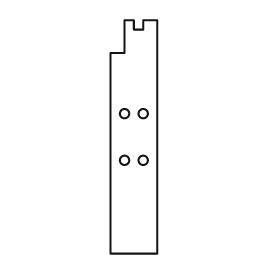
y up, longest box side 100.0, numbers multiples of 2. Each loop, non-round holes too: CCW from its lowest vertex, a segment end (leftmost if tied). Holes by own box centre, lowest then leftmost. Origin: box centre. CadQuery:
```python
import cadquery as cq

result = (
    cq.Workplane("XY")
    .moveTo(-10.0, -50.0)
    .lineTo(10.0, -50.0)
    .lineTo(10.0, 50.0)
    .lineTo(4.0, 50.0)
    .lineTo(4.0, 46.0)
    .lineTo(0.0, 46.0)
    .lineTo(0.0, 50.0)
    .lineTo(-4.0, 50.0)
    .lineTo(-4.0, 36.0)
    .lineTo(-10.0, 36.0)
    .close()
    .moveTo(-4.0, -10.0)
    .circle(2.0)
    .moveTo(4.0, -10.0)
    .circle(2.0)
    .moveTo(-4.0, 10.0)
    .circle(2.0)
    .moveTo(4.0, 10.0)
    .circle(2.0)
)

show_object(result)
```